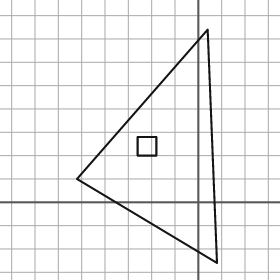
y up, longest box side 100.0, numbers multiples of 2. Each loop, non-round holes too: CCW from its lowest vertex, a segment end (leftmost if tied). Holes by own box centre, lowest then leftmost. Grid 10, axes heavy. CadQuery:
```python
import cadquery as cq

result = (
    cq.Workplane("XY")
    .moveTo(8.0, -26.0)
    .lineTo(4.0, 74.0)
    .lineTo(-52.0, 10.0)
    .close()
    .moveTo(-26.0, 20.0)
    .lineTo(-18.0, 20.0)
    .lineTo(-18.0, 28.0)
    .lineTo(-26.0, 28.0)
    .close()
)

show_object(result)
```